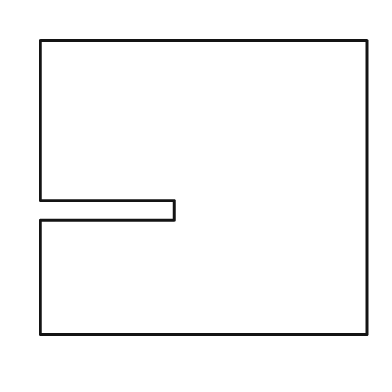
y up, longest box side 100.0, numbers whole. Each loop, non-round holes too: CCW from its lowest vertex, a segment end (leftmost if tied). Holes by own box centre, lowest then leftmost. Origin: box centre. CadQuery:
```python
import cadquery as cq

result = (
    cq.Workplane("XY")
    .moveTo(-50.0, -45.0)
    .lineTo(50.0, -45.0)
    .lineTo(50.0, 45.0)
    .lineTo(-50.0, 45.0)
    .lineTo(-50.0, -4.0)
    .lineTo(-9.0, -4.0)
    .lineTo(-9.0, -10.0)
    .lineTo(-50.0, -10.0)
    .close()
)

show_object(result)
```